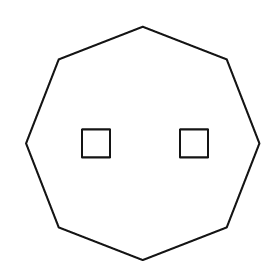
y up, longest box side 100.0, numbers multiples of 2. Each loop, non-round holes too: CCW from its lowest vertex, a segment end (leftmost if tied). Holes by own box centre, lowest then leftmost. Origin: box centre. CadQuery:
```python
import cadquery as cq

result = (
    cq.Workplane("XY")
    .moveTo(0.0, -50.0)
    .lineTo(36.0, -36.0)
    .lineTo(50.0, 0.0)
    .lineTo(36.0, 36.0)
    .lineTo(0.0, 50.0)
    .lineTo(-36.0, 36.0)
    .lineTo(-50.0, 0.0)
    .lineTo(-36.0, -36.0)
    .close()
    .moveTo(-26.0, -6.0)
    .lineTo(-14.0, -6.0)
    .lineTo(-14.0, 6.0)
    .lineTo(-26.0, 6.0)
    .close()
    .moveTo(16.0, -6.0)
    .lineTo(28.0, -6.0)
    .lineTo(28.0, 6.0)
    .lineTo(16.0, 6.0)
    .close()
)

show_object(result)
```